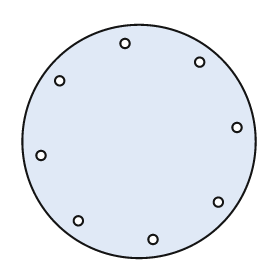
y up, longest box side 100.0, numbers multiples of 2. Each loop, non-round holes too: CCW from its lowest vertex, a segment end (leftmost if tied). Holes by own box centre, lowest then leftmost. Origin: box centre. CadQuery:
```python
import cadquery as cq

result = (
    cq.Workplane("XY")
    .moveTo(0.0, 0.0)
    .circle(50.0)
    .moveTo(6.0, -42.0)
    .circle(2.0)
    .moveTo(-26.0, -34.0)
    .circle(2.0)
    .moveTo(34.0, -26.0)
    .circle(2.0)
    .moveTo(-42.0, -6.0)
    .circle(2.0)
    .moveTo(42.0, 6.0)
    .circle(2.0)
    .moveTo(-34.0, 26.0)
    .circle(2.0)
    .moveTo(26.0, 34.0)
    .circle(2.0)
    .moveTo(-6.0, 42.0)
    .circle(2.0)
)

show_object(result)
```